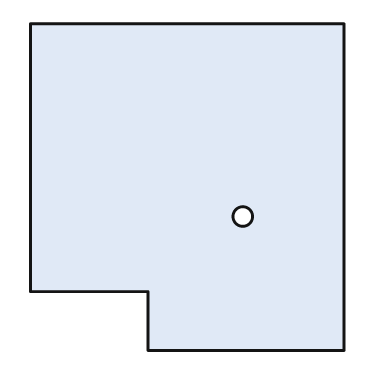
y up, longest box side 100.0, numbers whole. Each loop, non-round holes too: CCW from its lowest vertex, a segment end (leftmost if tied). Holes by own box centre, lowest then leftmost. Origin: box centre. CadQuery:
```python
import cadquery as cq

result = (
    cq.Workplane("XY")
    .moveTo(-12.0, -50.0)
    .lineTo(48.0, -50.0)
    .lineTo(48.0, 50.0)
    .lineTo(-48.0, 50.0)
    .lineTo(-48.0, -32.0)
    .lineTo(-12.0, -32.0)
    .close()
    .moveTo(17.0, -9.0)
    .circle(3.0)
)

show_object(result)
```